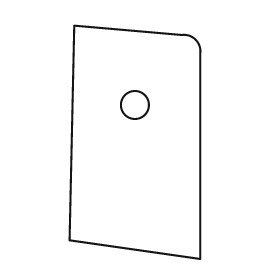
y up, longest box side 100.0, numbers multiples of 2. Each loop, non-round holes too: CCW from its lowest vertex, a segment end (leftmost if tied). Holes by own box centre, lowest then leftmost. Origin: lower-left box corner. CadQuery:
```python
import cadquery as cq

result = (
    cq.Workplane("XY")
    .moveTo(56.0, 0.0)
    .lineTo(56.0, 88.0)
    .threePointArc((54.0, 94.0), (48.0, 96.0))
    .lineTo(2.0, 100.0)
    .lineTo(0.0, 8.0)
    .close()
    .moveTo(28.0, 66.0)
    .circle(6.0)
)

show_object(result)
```